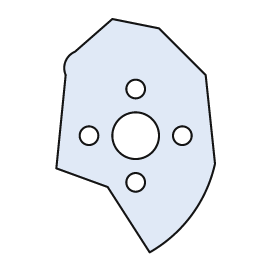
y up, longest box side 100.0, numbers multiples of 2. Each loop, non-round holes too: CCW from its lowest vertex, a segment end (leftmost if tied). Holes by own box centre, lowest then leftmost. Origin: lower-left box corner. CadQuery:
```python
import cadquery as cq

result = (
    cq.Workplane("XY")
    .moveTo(40.0, 0.0)
    .threePointArc((58.0, 16.0), (68.0, 38.0))
    .lineTo(64.0, 76.0)
    .lineTo(44.0, 96.0)
    .lineTo(24.0, 100.0)
    .lineTo(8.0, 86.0)
    .threePointArc((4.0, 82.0), (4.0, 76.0))
    .lineTo(0.0, 36.0)
    .lineTo(22.0, 28.0)
    .close()
    .moveTo(34.0, 30.0)
    .circle(4.0)
    .moveTo(14.0, 50.0)
    .circle(4.0)
    .moveTo(34.0, 50.0)
    .circle(10.0)
    .moveTo(54.0, 50.0)
    .circle(4.0)
    .moveTo(34.0, 70.0)
    .circle(4.0)
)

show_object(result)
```